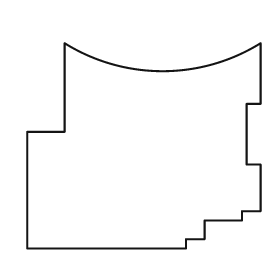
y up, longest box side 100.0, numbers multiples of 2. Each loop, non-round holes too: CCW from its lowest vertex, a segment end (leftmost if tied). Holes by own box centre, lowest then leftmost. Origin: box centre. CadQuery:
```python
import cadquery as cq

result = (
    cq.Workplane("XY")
    .moveTo(-50.0, -44.0)
    .lineTo(18.0, -44.0)
    .lineTo(18.0, -40.0)
    .lineTo(26.0, -40.0)
    .lineTo(26.0, -32.0)
    .lineTo(42.0, -32.0)
    .lineTo(42.0, -28.0)
    .lineTo(50.0, -28.0)
    .lineTo(50.0, -8.0)
    .lineTo(44.0, -8.0)
    .lineTo(44.0, 18.0)
    .lineTo(50.0, 18.0)
    .lineTo(50.0, 44.0)
    .threePointArc((8.0, 32.0), (-34.0, 44.0))
    .lineTo(-34.0, 6.0)
    .lineTo(-50.0, 6.0)
    .close()
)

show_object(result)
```